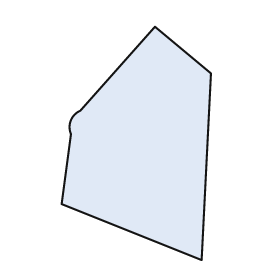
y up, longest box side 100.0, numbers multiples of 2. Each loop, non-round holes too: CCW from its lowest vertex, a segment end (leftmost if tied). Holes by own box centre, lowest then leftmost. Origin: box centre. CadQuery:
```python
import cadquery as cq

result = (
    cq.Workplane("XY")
    .moveTo(28.0, -50.0)
    .lineTo(32.0, 30.0)
    .lineTo(8.0, 50.0)
    .lineTo(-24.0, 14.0)
    .threePointArc((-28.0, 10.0), (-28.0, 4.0))
    .lineTo(-32.0, -26.0)
    .close()
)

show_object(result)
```